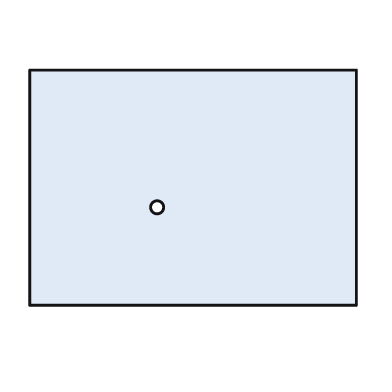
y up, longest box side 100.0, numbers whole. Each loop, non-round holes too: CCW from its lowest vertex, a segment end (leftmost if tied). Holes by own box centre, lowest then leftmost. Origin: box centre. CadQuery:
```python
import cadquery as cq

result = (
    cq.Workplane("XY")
    .moveTo(-50.0, -36.0)
    .lineTo(50.0, -36.0)
    .lineTo(50.0, 36.0)
    .lineTo(-50.0, 36.0)
    .close()
    .moveTo(-11.0, -6.0)
    .circle(2.0)
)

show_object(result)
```